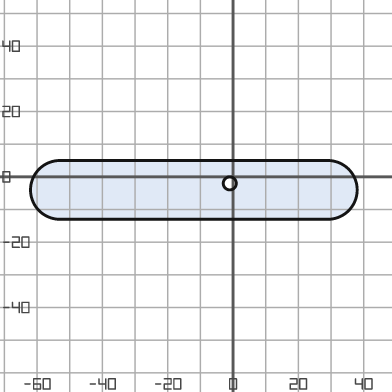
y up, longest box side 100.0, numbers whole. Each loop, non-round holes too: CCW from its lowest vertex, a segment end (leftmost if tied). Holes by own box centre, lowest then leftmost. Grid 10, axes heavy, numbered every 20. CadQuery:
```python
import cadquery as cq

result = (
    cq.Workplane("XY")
    .moveTo(-53.0, -13.0)
    .lineTo(29.0, -13.0)
    .threePointArc((38.0, -4.0), (29.0, 5.0))
    .lineTo(-53.0, 5.0)
    .threePointArc((-62.0, -4.0), (-53.0, -13.0))
    .close()
    .moveTo(-1.0, -2.0)
    .circle(2.0)
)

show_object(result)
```